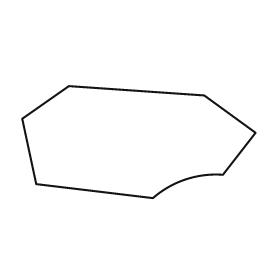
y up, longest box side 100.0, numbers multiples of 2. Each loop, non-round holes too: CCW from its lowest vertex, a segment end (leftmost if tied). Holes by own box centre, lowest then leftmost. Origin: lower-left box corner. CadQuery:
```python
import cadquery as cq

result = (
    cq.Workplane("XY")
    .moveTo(56.0, 0.0)
    .threePointArc((70.0, 8.0), (86.0, 10.0))
    .lineTo(100.0, 28.0)
    .lineTo(78.0, 44.0)
    .lineTo(20.0, 48.0)
    .lineTo(0.0, 34.0)
    .lineTo(6.0, 6.0)
    .close()
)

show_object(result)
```